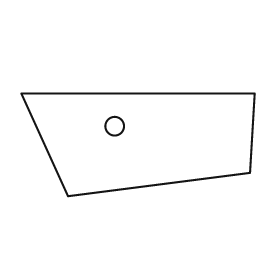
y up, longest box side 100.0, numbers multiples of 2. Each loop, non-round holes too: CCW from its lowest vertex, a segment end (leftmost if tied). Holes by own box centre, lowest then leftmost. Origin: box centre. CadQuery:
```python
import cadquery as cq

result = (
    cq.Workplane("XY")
    .moveTo(-30.0, -22.0)
    .lineTo(48.0, -12.0)
    .lineTo(50.0, 22.0)
    .lineTo(-50.0, 22.0)
    .close()
    .moveTo(-10.0, 8.0)
    .circle(4.0)
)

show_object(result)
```